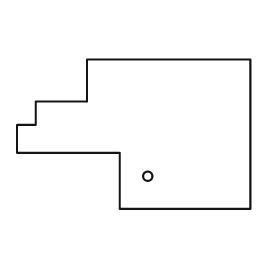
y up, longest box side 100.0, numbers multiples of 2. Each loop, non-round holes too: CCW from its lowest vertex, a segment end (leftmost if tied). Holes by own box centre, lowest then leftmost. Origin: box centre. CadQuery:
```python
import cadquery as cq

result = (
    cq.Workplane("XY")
    .moveTo(-6.0, -32.0)
    .lineTo(50.0, -32.0)
    .lineTo(50.0, 32.0)
    .lineTo(-20.0, 32.0)
    .lineTo(-20.0, 14.0)
    .lineTo(-42.0, 14.0)
    .lineTo(-42.0, 4.0)
    .lineTo(-50.0, 4.0)
    .lineTo(-50.0, -8.0)
    .lineTo(-6.0, -8.0)
    .close()
    .moveTo(6.0, -18.0)
    .circle(2.0)
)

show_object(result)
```